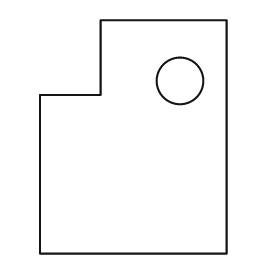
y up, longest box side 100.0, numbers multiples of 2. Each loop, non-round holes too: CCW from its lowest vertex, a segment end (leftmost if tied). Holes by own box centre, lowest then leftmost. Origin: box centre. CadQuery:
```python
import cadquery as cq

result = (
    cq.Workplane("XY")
    .moveTo(-40.0, -50.0)
    .lineTo(40.0, -50.0)
    .lineTo(40.0, 50.0)
    .lineTo(-14.0, 50.0)
    .lineTo(-14.0, 18.0)
    .lineTo(-40.0, 18.0)
    .close()
    .moveTo(20.0, 24.0)
    .circle(10.0)
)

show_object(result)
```